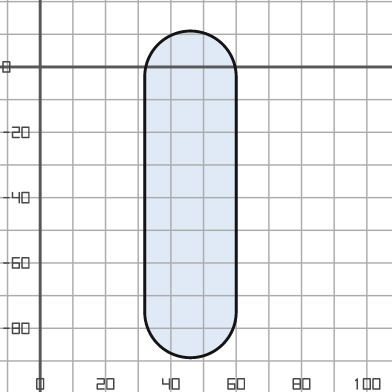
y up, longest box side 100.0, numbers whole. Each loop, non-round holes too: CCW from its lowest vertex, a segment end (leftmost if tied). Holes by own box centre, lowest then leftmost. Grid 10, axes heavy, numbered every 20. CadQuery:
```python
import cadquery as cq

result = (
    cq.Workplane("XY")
    .moveTo(32.0, -75.0)
    .threePointArc((46.0, -89.0), (60.0, -75.0))
    .lineTo(60.0, -3.0)
    .threePointArc((46.0, 11.0), (32.0, -3.0))
    .close()
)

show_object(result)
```